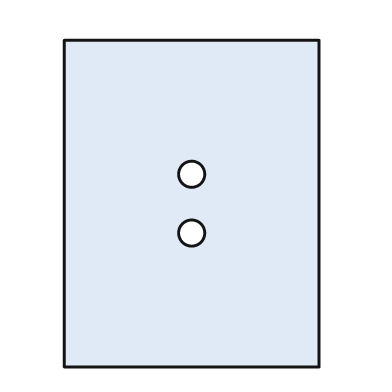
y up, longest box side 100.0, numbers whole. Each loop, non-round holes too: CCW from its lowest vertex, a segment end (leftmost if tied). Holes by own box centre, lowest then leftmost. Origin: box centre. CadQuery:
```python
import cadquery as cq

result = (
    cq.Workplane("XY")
    .moveTo(-39.0, -50.0)
    .lineTo(39.0, -50.0)
    .lineTo(39.0, 50.0)
    .lineTo(-39.0, 50.0)
    .close()
    .moveTo(0.0, -9.0)
    .circle(4.0)
    .moveTo(0.0, 9.0)
    .circle(4.0)
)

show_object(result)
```